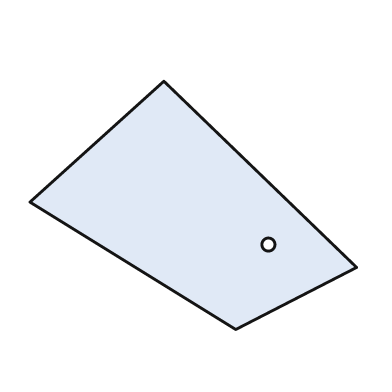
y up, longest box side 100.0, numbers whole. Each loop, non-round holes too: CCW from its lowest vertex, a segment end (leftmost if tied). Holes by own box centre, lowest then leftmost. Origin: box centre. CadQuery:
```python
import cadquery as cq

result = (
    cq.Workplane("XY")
    .moveTo(13.0, -38.0)
    .lineTo(50.0, -19.0)
    .lineTo(-9.0, 38.0)
    .lineTo(-50.0, 1.0)
    .close()
    .moveTo(23.0, -12.0)
    .circle(2.0)
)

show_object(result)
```